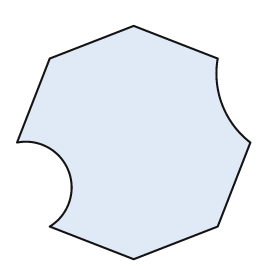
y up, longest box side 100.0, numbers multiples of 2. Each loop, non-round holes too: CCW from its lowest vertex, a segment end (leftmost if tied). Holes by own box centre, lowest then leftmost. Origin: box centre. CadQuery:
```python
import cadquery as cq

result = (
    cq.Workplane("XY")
    .moveTo(0.0, -50.0)
    .lineTo(36.0, -36.0)
    .lineTo(50.0, 0.0)
    .threePointArc((38.0, 16.0), (36.0, 36.0))
    .lineTo(0.0, 50.0)
    .lineTo(-36.0, 36.0)
    .lineTo(-50.0, 0.0)
    .threePointArc((-28.0, -12.0), (-36.0, -36.0))
    .close()
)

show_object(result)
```